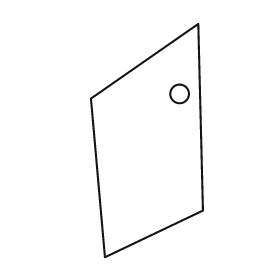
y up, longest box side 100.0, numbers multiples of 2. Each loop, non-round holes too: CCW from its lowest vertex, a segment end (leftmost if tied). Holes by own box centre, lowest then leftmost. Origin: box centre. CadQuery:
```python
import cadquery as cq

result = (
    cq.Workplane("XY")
    .moveTo(-18.0, -50.0)
    .lineTo(24.0, -30.0)
    .lineTo(22.0, 50.0)
    .lineTo(-24.0, 18.0)
    .close()
    .moveTo(14.0, 20.0)
    .circle(4.0)
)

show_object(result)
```